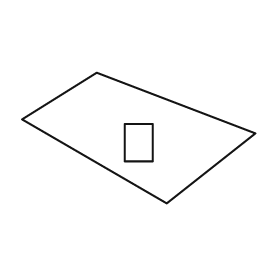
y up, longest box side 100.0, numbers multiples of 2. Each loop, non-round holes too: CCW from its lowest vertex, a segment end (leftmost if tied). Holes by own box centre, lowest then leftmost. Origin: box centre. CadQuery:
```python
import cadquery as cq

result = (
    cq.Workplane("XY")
    .moveTo(12.0, -28.0)
    .lineTo(50.0, 2.0)
    .lineTo(-18.0, 28.0)
    .lineTo(-50.0, 8.0)
    .close()
    .moveTo(-6.0, -10.0)
    .lineTo(6.0, -10.0)
    .lineTo(6.0, 6.0)
    .lineTo(-6.0, 6.0)
    .close()
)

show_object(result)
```